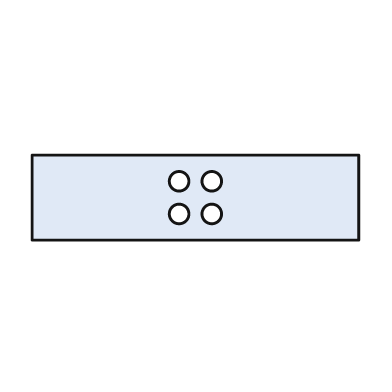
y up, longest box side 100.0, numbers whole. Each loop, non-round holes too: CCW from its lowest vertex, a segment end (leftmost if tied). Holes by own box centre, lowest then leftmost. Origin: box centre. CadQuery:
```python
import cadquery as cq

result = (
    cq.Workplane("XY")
    .moveTo(-50.0, -13.0)
    .lineTo(50.0, -13.0)
    .lineTo(50.0, 13.0)
    .lineTo(-50.0, 13.0)
    .close()
    .moveTo(-5.0, -5.0)
    .circle(3.0)
    .moveTo(5.0, -5.0)
    .circle(3.0)
    .moveTo(-5.0, 5.0)
    .circle(3.0)
    .moveTo(5.0, 5.0)
    .circle(3.0)
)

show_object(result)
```